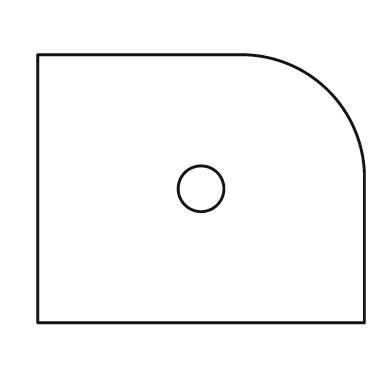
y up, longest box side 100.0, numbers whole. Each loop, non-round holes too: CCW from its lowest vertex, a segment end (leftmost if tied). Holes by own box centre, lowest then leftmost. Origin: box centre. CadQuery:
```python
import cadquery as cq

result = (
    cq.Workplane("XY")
    .moveTo(-50.0, -41.0)
    .lineTo(50.0, -41.0)
    .lineTo(50.0, 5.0)
    .threePointArc((39.0, 30.0), (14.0, 41.0))
    .lineTo(-50.0, 41.0)
    .close()
    .moveTo(0.0, 0.0)
    .circle(7.0)
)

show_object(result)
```